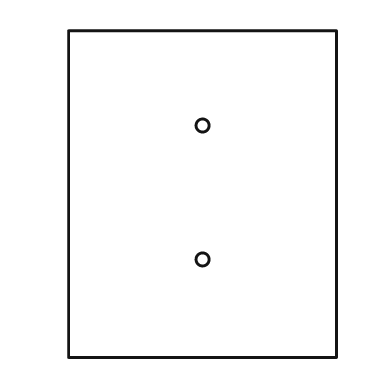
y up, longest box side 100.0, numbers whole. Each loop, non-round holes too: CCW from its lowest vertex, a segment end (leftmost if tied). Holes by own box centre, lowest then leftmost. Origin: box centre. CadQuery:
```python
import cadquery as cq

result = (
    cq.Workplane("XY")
    .moveTo(-41.0, -50.0)
    .lineTo(41.0, -50.0)
    .lineTo(41.0, 50.0)
    .lineTo(-41.0, 50.0)
    .close()
    .moveTo(0.0, -20.0)
    .circle(2.0)
    .moveTo(0.0, 21.0)
    .circle(2.0)
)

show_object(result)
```